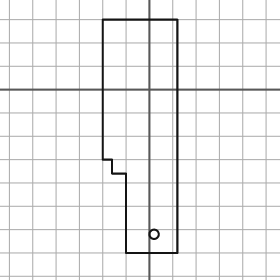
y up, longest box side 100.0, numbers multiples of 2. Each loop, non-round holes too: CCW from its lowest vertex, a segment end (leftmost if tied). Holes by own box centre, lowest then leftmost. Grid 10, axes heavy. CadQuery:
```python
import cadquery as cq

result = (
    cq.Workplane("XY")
    .moveTo(-10.0, -70.0)
    .lineTo(12.0, -70.0)
    .lineTo(12.0, 30.0)
    .lineTo(-20.0, 30.0)
    .lineTo(-20.0, -30.0)
    .lineTo(-16.0, -30.0)
    .lineTo(-16.0, -36.0)
    .lineTo(-10.0, -36.0)
    .close()
    .moveTo(2.0, -62.0)
    .circle(2.0)
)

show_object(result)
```